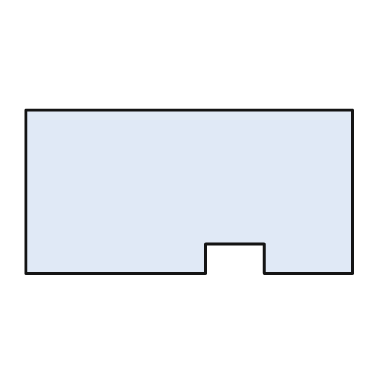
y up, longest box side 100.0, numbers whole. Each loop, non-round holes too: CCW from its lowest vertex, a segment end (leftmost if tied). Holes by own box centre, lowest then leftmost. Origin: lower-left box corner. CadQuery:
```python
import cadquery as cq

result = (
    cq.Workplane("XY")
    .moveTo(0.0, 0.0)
    .lineTo(55.0, 0.0)
    .lineTo(55.0, 9.0)
    .lineTo(73.0, 9.0)
    .lineTo(73.0, 0.0)
    .lineTo(100.0, 0.0)
    .lineTo(100.0, 50.0)
    .lineTo(0.0, 50.0)
    .close()
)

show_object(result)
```